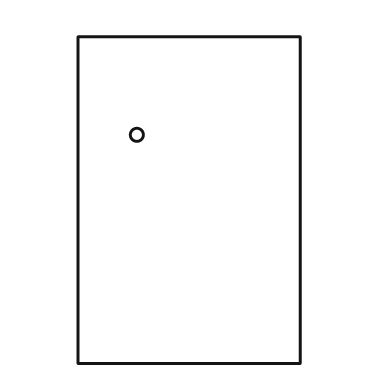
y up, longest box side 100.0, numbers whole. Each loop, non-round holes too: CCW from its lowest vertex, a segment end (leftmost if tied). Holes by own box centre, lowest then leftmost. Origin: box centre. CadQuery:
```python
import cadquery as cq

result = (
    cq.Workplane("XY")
    .moveTo(-34.0, -50.0)
    .lineTo(34.0, -50.0)
    .lineTo(34.0, 50.0)
    .lineTo(-34.0, 50.0)
    .close()
    .moveTo(-16.0, 20.0)
    .circle(2.0)
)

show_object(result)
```